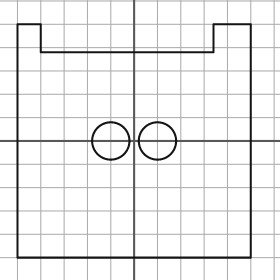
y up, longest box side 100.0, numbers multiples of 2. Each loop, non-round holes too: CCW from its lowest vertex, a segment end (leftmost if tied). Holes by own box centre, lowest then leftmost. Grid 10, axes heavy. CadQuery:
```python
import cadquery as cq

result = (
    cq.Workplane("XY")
    .moveTo(-50.0, -50.0)
    .lineTo(50.0, -50.0)
    .lineTo(50.0, 50.0)
    .lineTo(34.0, 50.0)
    .lineTo(34.0, 38.0)
    .lineTo(-40.0, 38.0)
    .lineTo(-40.0, 50.0)
    .lineTo(-50.0, 50.0)
    .close()
    .moveTo(-10.0, 0.0)
    .circle(8.0)
    .moveTo(10.0, 0.0)
    .circle(8.0)
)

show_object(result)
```